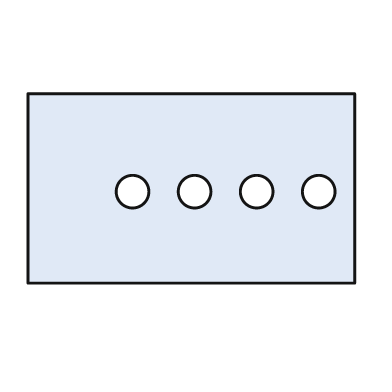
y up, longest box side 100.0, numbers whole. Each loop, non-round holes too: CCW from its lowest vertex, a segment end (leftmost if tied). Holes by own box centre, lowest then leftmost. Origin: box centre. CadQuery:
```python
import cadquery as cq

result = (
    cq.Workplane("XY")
    .moveTo(-50.0, -29.0)
    .lineTo(50.0, -29.0)
    .lineTo(50.0, 29.0)
    .lineTo(-50.0, 29.0)
    .close()
    .moveTo(-18.0, -1.0)
    .circle(5.0)
    .moveTo(1.0, -1.0)
    .circle(5.0)
    .moveTo(20.0, -1.0)
    .circle(5.0)
    .moveTo(39.0, -1.0)
    .circle(5.0)
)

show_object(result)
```